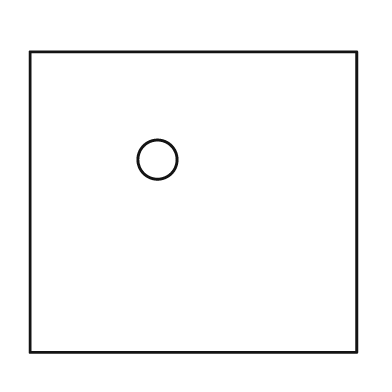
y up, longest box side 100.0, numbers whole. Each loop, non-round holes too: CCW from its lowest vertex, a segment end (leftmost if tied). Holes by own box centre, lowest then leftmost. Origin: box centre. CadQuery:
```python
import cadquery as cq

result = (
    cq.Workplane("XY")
    .moveTo(-50.0, -46.0)
    .lineTo(50.0, -46.0)
    .lineTo(50.0, 46.0)
    .lineTo(-50.0, 46.0)
    .close()
    .moveTo(-11.0, 13.0)
    .circle(6.0)
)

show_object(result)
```